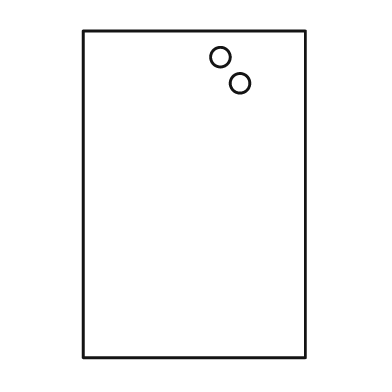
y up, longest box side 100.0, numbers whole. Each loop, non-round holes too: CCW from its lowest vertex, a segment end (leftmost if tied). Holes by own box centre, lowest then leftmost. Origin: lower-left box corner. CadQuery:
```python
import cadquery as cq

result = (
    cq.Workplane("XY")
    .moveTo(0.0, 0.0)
    .lineTo(68.0, 0.0)
    .lineTo(68.0, 100.0)
    .lineTo(0.0, 100.0)
    .close()
    .moveTo(48.0, 84.0)
    .circle(3.0)
    .moveTo(42.0, 92.0)
    .circle(3.0)
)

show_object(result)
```